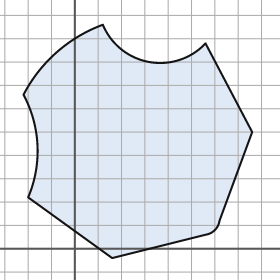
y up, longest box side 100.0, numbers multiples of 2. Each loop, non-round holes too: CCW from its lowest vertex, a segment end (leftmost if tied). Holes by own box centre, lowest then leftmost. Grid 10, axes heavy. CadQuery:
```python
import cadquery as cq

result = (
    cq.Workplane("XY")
    .moveTo(16.0, -4.0)
    .lineTo(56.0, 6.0)
    .threePointArc((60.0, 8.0), (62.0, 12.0))
    .lineTo(76.0, 50.0)
    .lineTo(56.0, 88.0)
    .threePointArc((32.0, 80.0), (12.0, 96.0))
    .threePointArc((-8.0, 84.0), (-22.0, 66.0))
    .threePointArc((-16.0, 44.0), (-20.0, 22.0))
    .close()
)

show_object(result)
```